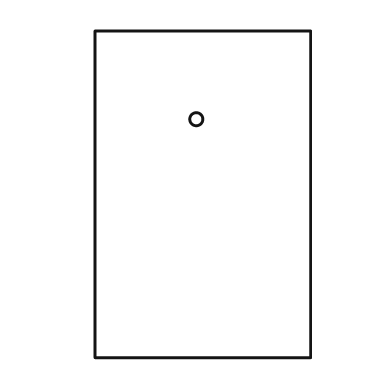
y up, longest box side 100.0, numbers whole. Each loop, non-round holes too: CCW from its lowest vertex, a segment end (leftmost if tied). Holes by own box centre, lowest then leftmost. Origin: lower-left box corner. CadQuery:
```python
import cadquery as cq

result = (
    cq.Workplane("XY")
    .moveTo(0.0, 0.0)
    .lineTo(66.0, 0.0)
    .lineTo(66.0, 100.0)
    .lineTo(0.0, 100.0)
    .close()
    .moveTo(31.0, 73.0)
    .circle(2.0)
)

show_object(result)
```